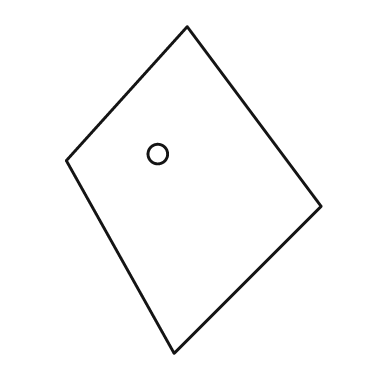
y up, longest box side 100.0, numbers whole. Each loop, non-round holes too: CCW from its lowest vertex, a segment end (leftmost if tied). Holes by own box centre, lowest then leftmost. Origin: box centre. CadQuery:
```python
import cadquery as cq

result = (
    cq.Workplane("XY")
    .moveTo(-6.0, -50.0)
    .lineTo(39.0, -5.0)
    .lineTo(-2.0, 50.0)
    .lineTo(-39.0, 9.0)
    .close()
    .moveTo(-11.0, 11.0)
    .circle(3.0)
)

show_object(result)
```